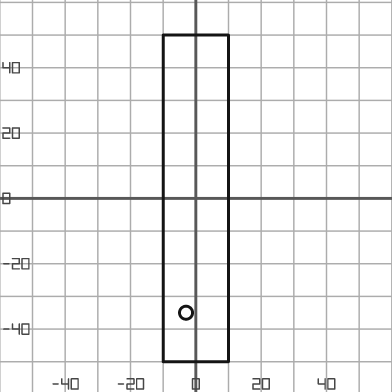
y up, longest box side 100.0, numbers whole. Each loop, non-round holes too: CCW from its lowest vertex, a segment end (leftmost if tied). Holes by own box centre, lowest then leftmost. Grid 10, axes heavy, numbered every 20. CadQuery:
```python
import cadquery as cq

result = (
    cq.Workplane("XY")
    .moveTo(-10.0, -50.0)
    .lineTo(10.0, -50.0)
    .lineTo(10.0, 50.0)
    .lineTo(-10.0, 50.0)
    .close()
    .moveTo(-3.0, -35.0)
    .circle(2.0)
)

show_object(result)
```